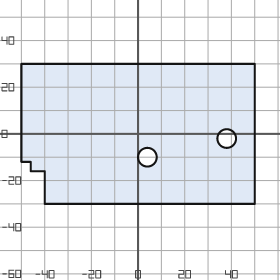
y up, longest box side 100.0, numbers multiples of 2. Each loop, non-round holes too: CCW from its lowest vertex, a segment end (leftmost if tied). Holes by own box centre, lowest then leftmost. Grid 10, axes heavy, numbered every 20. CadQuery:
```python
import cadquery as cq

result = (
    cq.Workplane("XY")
    .moveTo(-40.0, -30.0)
    .lineTo(50.0, -30.0)
    .lineTo(50.0, 30.0)
    .lineTo(-50.0, 30.0)
    .lineTo(-50.0, -12.0)
    .lineTo(-46.0, -12.0)
    .lineTo(-46.0, -16.0)
    .lineTo(-40.0, -16.0)
    .close()
    .moveTo(4.0, -10.0)
    .circle(4.0)
    .moveTo(38.0, -2.0)
    .circle(4.0)
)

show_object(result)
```